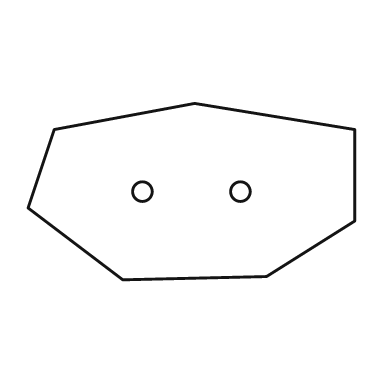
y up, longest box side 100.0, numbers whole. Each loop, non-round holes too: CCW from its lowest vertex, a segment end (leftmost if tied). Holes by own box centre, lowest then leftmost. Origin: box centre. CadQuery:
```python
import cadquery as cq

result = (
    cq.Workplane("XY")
    .moveTo(-21.0, -27.0)
    .lineTo(23.0, -26.0)
    .lineTo(50.0, -9.0)
    .lineTo(50.0, 19.0)
    .lineTo(1.0, 27.0)
    .lineTo(-42.0, 19.0)
    .lineTo(-50.0, -5.0)
    .close()
    .moveTo(-15.0, 0.0)
    .circle(3.0)
    .moveTo(15.0, 0.0)
    .circle(3.0)
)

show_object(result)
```